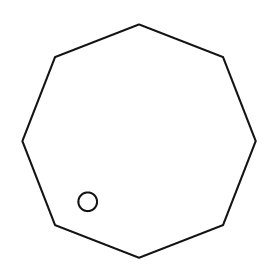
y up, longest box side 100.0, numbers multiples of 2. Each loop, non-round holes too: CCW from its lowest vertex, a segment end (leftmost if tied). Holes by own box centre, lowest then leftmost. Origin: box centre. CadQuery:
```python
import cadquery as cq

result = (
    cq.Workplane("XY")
    .moveTo(0.0, -50.0)
    .lineTo(36.0, -36.0)
    .lineTo(50.0, 0.0)
    .lineTo(36.0, 36.0)
    .lineTo(0.0, 50.0)
    .lineTo(-36.0, 36.0)
    .lineTo(-50.0, 0.0)
    .lineTo(-36.0, -36.0)
    .close()
    .moveTo(-22.0, -26.0)
    .circle(4.0)
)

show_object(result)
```